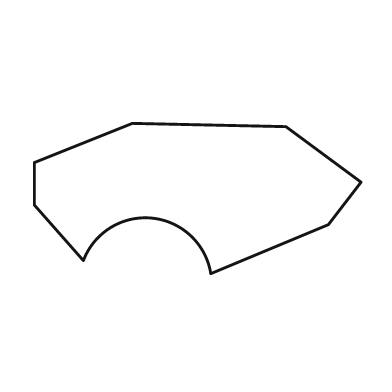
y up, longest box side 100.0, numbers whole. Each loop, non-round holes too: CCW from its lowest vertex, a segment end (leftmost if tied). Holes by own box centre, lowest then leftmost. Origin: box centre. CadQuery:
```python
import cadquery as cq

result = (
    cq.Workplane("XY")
    .moveTo(4.0, -23.0)
    .lineTo(40.0, -8.0)
    .lineTo(50.0, 5.0)
    .lineTo(27.0, 22.0)
    .lineTo(-20.0, 23.0)
    .lineTo(-50.0, 11.0)
    .lineTo(-50.0, -2.0)
    .lineTo(-35.0, -19.0)
    .threePointArc((-14.0, -6.0), (4.0, -23.0))
    .close()
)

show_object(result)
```